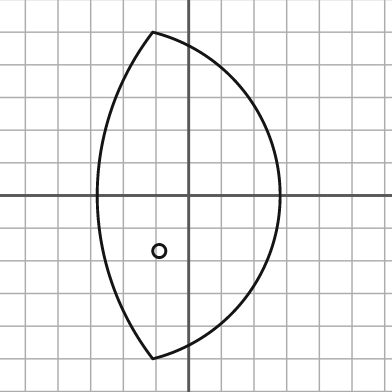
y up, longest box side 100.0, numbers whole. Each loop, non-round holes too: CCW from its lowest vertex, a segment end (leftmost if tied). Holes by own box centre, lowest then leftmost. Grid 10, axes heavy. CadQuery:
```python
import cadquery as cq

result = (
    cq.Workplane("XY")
    .moveTo(-11.0, -50.0)
    .threePointArc((28.0, 0.0), (-11.0, 50.0))
    .threePointArc((-28.0, 0.0), (-11.0, -50.0))
    .close()
    .moveTo(-9.0, -17.0)
    .circle(2.0)
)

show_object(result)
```